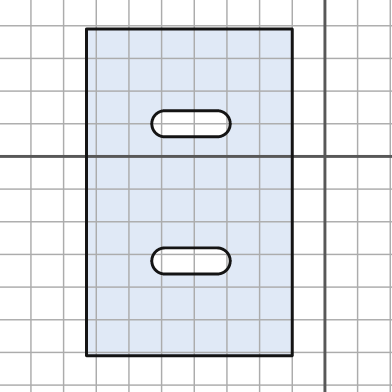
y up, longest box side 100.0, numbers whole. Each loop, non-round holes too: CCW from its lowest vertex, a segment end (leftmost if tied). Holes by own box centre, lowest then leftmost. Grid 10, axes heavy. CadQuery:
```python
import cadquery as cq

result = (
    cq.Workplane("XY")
    .moveTo(-73.0, -61.0)
    .lineTo(-10.0, -61.0)
    .lineTo(-10.0, 39.0)
    .lineTo(-73.0, 39.0)
    .close()
    .moveTo(-49.0, -36.0)
    .lineTo(-33.0, -36.0)
    .threePointArc((-29.0, -32.0), (-33.0, -28.0))
    .lineTo(-49.0, -28.0)
    .threePointArc((-53.0, -32.0), (-49.0, -36.0))
    .close()
    .moveTo(-49.0, 6.0)
    .lineTo(-33.0, 6.0)
    .threePointArc((-29.0, 10.0), (-33.0, 14.0))
    .lineTo(-49.0, 14.0)
    .threePointArc((-53.0, 10.0), (-49.0, 6.0))
    .close()
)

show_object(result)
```